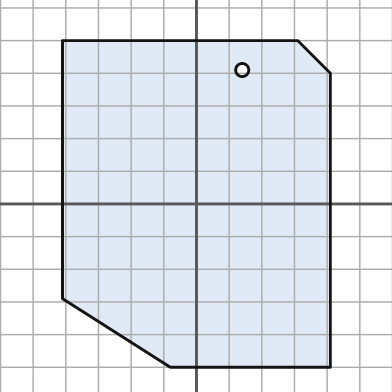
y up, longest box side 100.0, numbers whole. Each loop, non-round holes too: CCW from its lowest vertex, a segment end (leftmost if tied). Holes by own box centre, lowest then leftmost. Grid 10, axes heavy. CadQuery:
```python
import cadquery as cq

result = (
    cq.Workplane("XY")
    .moveTo(-8.0, -50.0)
    .lineTo(41.0, -50.0)
    .lineTo(41.0, 40.0)
    .lineTo(31.0, 50.0)
    .lineTo(-41.0, 50.0)
    .lineTo(-41.0, -29.0)
    .close()
    .moveTo(14.0, 41.0)
    .circle(2.0)
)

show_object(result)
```